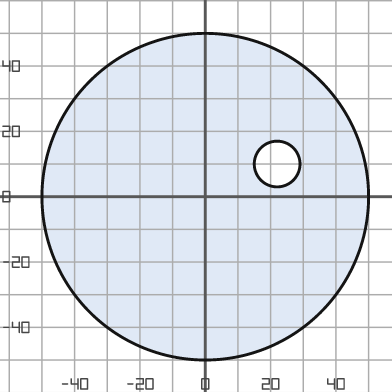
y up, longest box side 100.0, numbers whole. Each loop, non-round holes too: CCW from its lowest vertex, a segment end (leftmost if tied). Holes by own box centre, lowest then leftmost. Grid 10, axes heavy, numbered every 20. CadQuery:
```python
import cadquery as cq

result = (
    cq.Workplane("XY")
    .moveTo(0.0, 0.0)
    .circle(50.0)
    .moveTo(22.0, 10.0)
    .circle(7.0)
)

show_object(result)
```